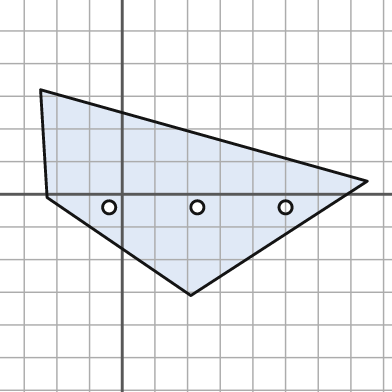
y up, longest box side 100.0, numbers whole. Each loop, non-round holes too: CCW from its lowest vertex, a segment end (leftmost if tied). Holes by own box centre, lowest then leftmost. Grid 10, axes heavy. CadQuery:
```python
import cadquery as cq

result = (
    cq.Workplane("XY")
    .moveTo(21.0, -31.0)
    .lineTo(75.0, 4.0)
    .lineTo(-25.0, 32.0)
    .lineTo(-23.0, -1.0)
    .close()
    .moveTo(-4.0, -4.0)
    .circle(2.0)
    .moveTo(23.0, -4.0)
    .circle(2.0)
    .moveTo(50.0, -4.0)
    .circle(2.0)
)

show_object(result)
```